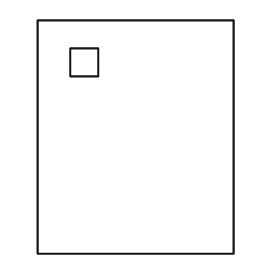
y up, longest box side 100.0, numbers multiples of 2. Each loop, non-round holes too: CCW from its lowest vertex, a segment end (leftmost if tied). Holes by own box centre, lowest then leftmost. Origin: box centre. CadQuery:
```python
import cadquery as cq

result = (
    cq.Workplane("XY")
    .moveTo(-42.0, -50.0)
    .lineTo(42.0, -50.0)
    .lineTo(42.0, 50.0)
    .lineTo(-42.0, 50.0)
    .close()
    .moveTo(-28.0, 26.0)
    .lineTo(-16.0, 26.0)
    .lineTo(-16.0, 38.0)
    .lineTo(-28.0, 38.0)
    .close()
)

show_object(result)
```